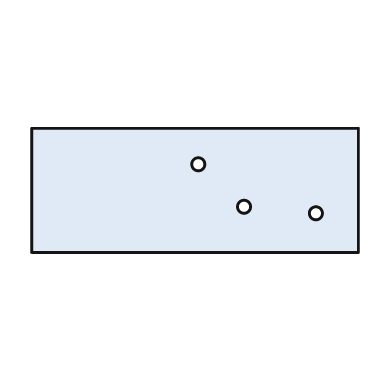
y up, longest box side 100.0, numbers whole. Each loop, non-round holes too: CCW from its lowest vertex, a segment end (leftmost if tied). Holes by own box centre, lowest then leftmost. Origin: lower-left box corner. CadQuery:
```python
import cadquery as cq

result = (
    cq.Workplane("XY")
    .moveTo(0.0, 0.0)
    .lineTo(100.0, 0.0)
    .lineTo(100.0, 38.0)
    .lineTo(0.0, 38.0)
    .close()
    .moveTo(87.0, 12.0)
    .circle(2.0)
    .moveTo(65.0, 14.0)
    .circle(2.0)
    .moveTo(51.0, 27.0)
    .circle(2.0)
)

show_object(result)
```